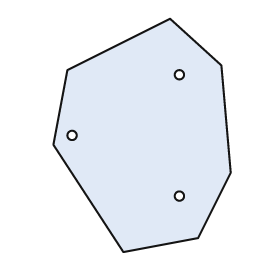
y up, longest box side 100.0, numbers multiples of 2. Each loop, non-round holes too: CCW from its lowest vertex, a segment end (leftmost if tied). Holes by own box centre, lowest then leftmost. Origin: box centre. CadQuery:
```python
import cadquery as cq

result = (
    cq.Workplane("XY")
    .moveTo(-8.0, -50.0)
    .lineTo(24.0, -44.0)
    .lineTo(38.0, -16.0)
    .lineTo(34.0, 30.0)
    .lineTo(12.0, 50.0)
    .lineTo(-32.0, 28.0)
    .lineTo(-38.0, -4.0)
    .close()
    .moveTo(16.0, -26.0)
    .circle(2.0)
    .moveTo(-30.0, 0.0)
    .circle(2.0)
    .moveTo(16.0, 26.0)
    .circle(2.0)
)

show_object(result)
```